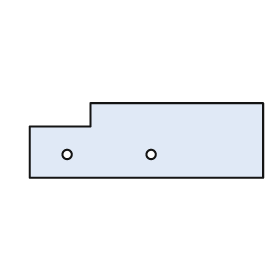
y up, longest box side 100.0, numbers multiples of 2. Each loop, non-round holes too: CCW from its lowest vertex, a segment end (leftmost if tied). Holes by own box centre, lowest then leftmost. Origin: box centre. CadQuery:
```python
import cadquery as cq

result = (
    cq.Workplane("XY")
    .moveTo(-50.0, -16.0)
    .lineTo(50.0, -16.0)
    .lineTo(50.0, 16.0)
    .lineTo(-24.0, 16.0)
    .lineTo(-24.0, 6.0)
    .lineTo(-50.0, 6.0)
    .close()
    .moveTo(-34.0, -6.0)
    .circle(2.0)
    .moveTo(2.0, -6.0)
    .circle(2.0)
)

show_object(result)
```